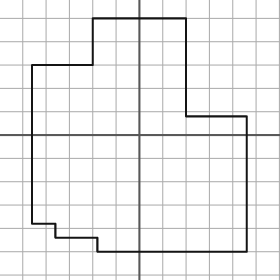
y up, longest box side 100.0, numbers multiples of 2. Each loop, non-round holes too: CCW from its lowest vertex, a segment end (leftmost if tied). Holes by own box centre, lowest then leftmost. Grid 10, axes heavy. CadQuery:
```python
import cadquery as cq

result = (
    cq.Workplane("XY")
    .moveTo(-18.0, -50.0)
    .lineTo(46.0, -50.0)
    .lineTo(46.0, 8.0)
    .lineTo(20.0, 8.0)
    .lineTo(20.0, 50.0)
    .lineTo(-20.0, 50.0)
    .lineTo(-20.0, 30.0)
    .lineTo(-46.0, 30.0)
    .lineTo(-46.0, -38.0)
    .lineTo(-36.0, -38.0)
    .lineTo(-36.0, -44.0)
    .lineTo(-18.0, -44.0)
    .close()
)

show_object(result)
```